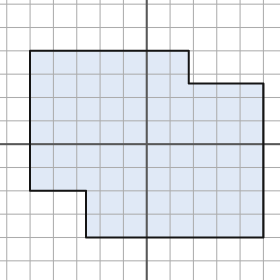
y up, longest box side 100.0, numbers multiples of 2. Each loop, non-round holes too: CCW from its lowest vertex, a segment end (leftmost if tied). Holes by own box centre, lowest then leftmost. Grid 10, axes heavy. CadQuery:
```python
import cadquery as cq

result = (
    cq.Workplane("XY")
    .moveTo(-26.0, -40.0)
    .lineTo(50.0, -40.0)
    .lineTo(50.0, 26.0)
    .lineTo(18.0, 26.0)
    .lineTo(18.0, 40.0)
    .lineTo(-50.0, 40.0)
    .lineTo(-50.0, -20.0)
    .lineTo(-26.0, -20.0)
    .close()
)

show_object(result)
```